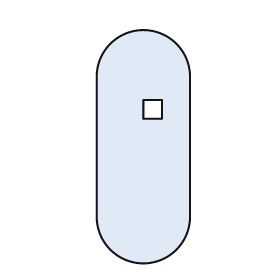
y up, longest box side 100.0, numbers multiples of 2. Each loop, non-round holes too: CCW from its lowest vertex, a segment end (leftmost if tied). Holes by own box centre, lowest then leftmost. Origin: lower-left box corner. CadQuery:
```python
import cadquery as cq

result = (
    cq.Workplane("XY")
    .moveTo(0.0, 20.0)
    .threePointArc((20.0, 0.0), (40.0, 20.0))
    .lineTo(40.0, 80.0)
    .threePointArc((20.0, 100.0), (0.0, 80.0))
    .close()
    .moveTo(20.0, 62.0)
    .lineTo(28.0, 62.0)
    .lineTo(28.0, 70.0)
    .lineTo(20.0, 70.0)
    .close()
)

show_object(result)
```